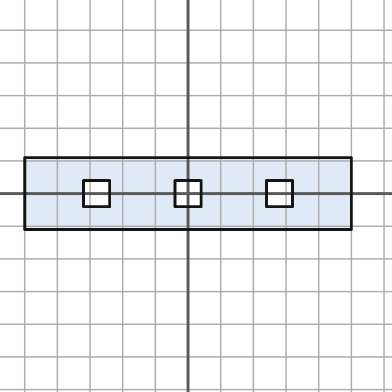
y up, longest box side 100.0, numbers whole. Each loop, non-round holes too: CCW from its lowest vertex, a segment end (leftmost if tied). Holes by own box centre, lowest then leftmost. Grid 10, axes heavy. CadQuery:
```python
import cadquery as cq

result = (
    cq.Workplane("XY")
    .moveTo(-50.0, -11.0)
    .lineTo(50.0, -11.0)
    .lineTo(50.0, 11.0)
    .lineTo(-50.0, 11.0)
    .close()
    .moveTo(-32.0, -4.0)
    .lineTo(-24.0, -4.0)
    .lineTo(-24.0, 4.0)
    .lineTo(-32.0, 4.0)
    .close()
    .moveTo(-4.0, -4.0)
    .lineTo(4.0, -4.0)
    .lineTo(4.0, 4.0)
    .lineTo(-4.0, 4.0)
    .close()
    .moveTo(24.0, -4.0)
    .lineTo(32.0, -4.0)
    .lineTo(32.0, 4.0)
    .lineTo(24.0, 4.0)
    .close()
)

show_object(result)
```